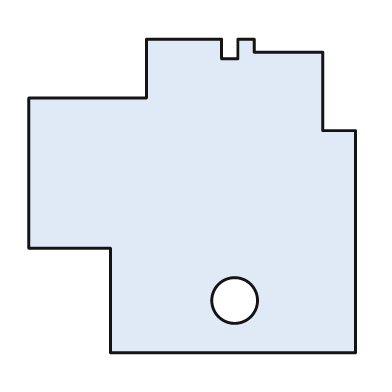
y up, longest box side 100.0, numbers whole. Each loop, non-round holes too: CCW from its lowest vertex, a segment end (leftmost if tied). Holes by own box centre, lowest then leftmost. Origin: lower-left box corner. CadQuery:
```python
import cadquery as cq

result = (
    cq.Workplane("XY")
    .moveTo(25.0, 0.0)
    .lineTo(100.0, 0.0)
    .lineTo(100.0, 68.0)
    .lineTo(90.0, 68.0)
    .lineTo(90.0, 92.0)
    .lineTo(69.0, 92.0)
    .lineTo(69.0, 96.0)
    .lineTo(64.0, 96.0)
    .lineTo(64.0, 90.0)
    .lineTo(59.0, 90.0)
    .lineTo(59.0, 96.0)
    .lineTo(36.0, 96.0)
    .lineTo(36.0, 78.0)
    .lineTo(0.0, 78.0)
    .lineTo(0.0, 32.0)
    .lineTo(25.0, 32.0)
    .close()
    .moveTo(63.0, 16.0)
    .circle(7.0)
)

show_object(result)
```